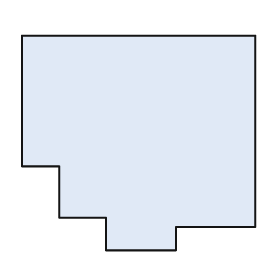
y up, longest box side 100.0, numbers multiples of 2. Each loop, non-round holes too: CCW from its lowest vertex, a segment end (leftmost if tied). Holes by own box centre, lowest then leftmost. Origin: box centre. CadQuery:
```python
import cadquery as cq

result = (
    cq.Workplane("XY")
    .moveTo(-14.0, -46.0)
    .lineTo(16.0, -46.0)
    .lineTo(16.0, -36.0)
    .lineTo(50.0, -36.0)
    .lineTo(50.0, 46.0)
    .lineTo(-50.0, 46.0)
    .lineTo(-50.0, -10.0)
    .lineTo(-34.0, -10.0)
    .lineTo(-34.0, -32.0)
    .lineTo(-14.0, -32.0)
    .close()
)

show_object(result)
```